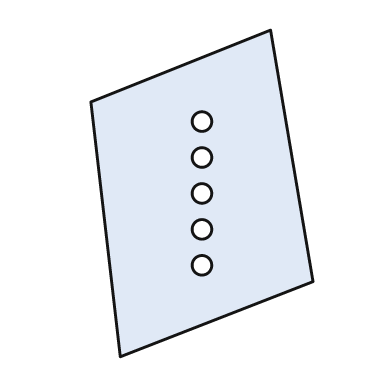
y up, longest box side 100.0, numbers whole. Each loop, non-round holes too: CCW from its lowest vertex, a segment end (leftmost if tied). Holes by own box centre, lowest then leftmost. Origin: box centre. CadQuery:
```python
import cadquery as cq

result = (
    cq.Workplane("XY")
    .moveTo(-25.0, -50.0)
    .lineTo(34.0, -27.0)
    .lineTo(21.0, 50.0)
    .lineTo(-34.0, 28.0)
    .close()
    .moveTo(0.0, -22.0)
    .circle(3.0)
    .moveTo(0.0, -11.0)
    .circle(3.0)
    .moveTo(0.0, 0.0)
    .circle(3.0)
    .moveTo(0.0, 11.0)
    .circle(3.0)
    .moveTo(0.0, 22.0)
    .circle(3.0)
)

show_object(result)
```